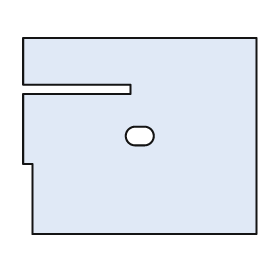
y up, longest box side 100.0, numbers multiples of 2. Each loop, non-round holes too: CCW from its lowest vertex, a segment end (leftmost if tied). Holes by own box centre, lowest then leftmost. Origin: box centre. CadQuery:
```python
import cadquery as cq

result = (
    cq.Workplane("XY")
    .moveTo(-46.0, -42.0)
    .lineTo(50.0, -42.0)
    .lineTo(50.0, 42.0)
    .lineTo(-50.0, 42.0)
    .lineTo(-50.0, 22.0)
    .lineTo(-4.0, 22.0)
    .lineTo(-4.0, 18.0)
    .lineTo(-50.0, 18.0)
    .lineTo(-50.0, -12.0)
    .lineTo(-46.0, -12.0)
    .close()
    .moveTo(-2.0, -4.0)
    .lineTo(2.0, -4.0)
    .threePointArc((6.0, 0.0), (2.0, 4.0))
    .lineTo(-2.0, 4.0)
    .threePointArc((-6.0, 0.0), (-2.0, -4.0))
    .close()
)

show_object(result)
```